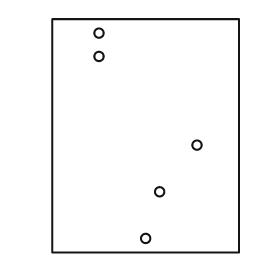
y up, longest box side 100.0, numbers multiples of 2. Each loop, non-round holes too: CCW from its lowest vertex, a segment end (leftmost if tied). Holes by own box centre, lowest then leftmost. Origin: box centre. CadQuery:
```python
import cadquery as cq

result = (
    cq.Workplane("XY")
    .moveTo(-40.0, -50.0)
    .lineTo(40.0, -50.0)
    .lineTo(40.0, 50.0)
    .lineTo(-40.0, 50.0)
    .close()
    .moveTo(0.0, -44.0)
    .circle(2.0)
    .moveTo(6.0, -24.0)
    .circle(2.0)
    .moveTo(22.0, -4.0)
    .circle(2.0)
    .moveTo(-20.0, 34.0)
    .circle(2.0)
    .moveTo(-20.0, 44.0)
    .circle(2.0)
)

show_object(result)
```